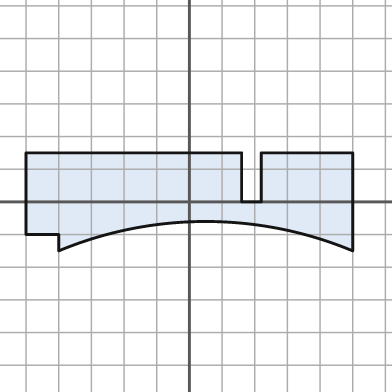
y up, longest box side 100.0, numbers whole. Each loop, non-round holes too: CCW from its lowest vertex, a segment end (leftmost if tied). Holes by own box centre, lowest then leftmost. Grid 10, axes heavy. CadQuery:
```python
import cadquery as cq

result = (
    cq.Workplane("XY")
    .moveTo(-40.0, -15.0)
    .threePointArc((5.0, -6.0), (50.0, -15.0))
    .lineTo(50.0, 15.0)
    .lineTo(22.0, 15.0)
    .lineTo(22.0, 0.0)
    .lineTo(16.0, 0.0)
    .lineTo(16.0, 15.0)
    .lineTo(-50.0, 15.0)
    .lineTo(-50.0, -10.0)
    .lineTo(-40.0, -10.0)
    .close()
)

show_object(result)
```